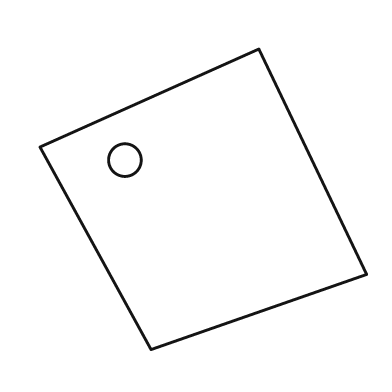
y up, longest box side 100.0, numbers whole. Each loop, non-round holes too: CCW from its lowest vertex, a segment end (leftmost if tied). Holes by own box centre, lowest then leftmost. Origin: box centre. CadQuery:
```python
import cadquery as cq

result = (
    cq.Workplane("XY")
    .moveTo(-16.0, -46.0)
    .lineTo(50.0, -23.0)
    .lineTo(17.0, 46.0)
    .lineTo(-50.0, 16.0)
    .close()
    .moveTo(-24.0, 12.0)
    .circle(5.0)
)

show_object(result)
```